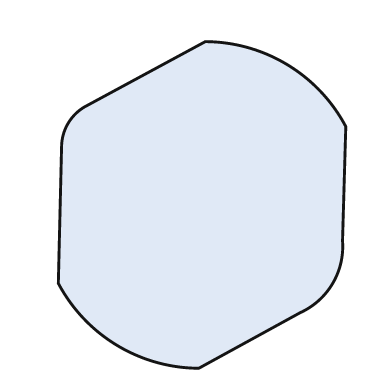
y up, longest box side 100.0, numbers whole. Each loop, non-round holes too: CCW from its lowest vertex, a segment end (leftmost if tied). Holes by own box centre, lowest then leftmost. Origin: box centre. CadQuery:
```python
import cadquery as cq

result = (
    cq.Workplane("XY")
    .moveTo(-1.0, -50.0)
    .lineTo(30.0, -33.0)
    .threePointArc((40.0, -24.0), (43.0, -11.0))
    .lineTo(44.0, 24.0)
    .threePointArc((26.0, 43.0), (1.0, 50.0))
    .lineTo(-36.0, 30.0)
    .threePointArc((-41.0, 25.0), (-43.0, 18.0))
    .lineTo(-44.0, -24.0)
    .threePointArc((-26.0, -43.0), (-1.0, -50.0))
    .close()
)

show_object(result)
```